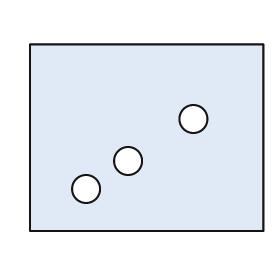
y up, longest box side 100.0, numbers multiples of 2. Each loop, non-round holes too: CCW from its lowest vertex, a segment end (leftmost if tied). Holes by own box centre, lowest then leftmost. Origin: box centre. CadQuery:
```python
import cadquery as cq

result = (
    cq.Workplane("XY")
    .moveTo(-50.0, -40.0)
    .lineTo(50.0, -40.0)
    .lineTo(50.0, 40.0)
    .lineTo(-50.0, 40.0)
    .close()
    .moveTo(-26.0, -22.0)
    .circle(6.0)
    .moveTo(-8.0, -10.0)
    .circle(6.0)
    .moveTo(20.0, 8.0)
    .circle(6.0)
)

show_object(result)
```